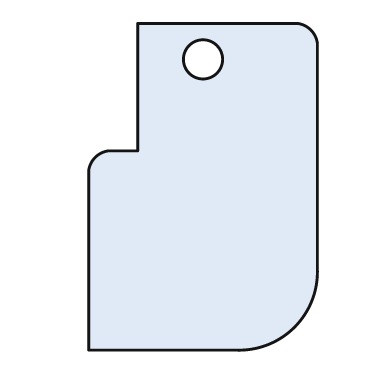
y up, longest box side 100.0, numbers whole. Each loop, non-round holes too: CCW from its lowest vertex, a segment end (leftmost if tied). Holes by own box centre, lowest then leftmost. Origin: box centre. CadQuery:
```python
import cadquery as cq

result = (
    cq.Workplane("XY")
    .moveTo(-35.0, -50.0)
    .lineTo(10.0, -50.0)
    .threePointArc((28.0, -43.0), (35.0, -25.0))
    .lineTo(35.0, 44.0)
    .threePointArc((33.0, 48.0), (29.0, 50.0))
    .lineTo(-20.0, 50.0)
    .lineTo(-20.0, 11.0)
    .lineTo(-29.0, 11.0)
    .threePointArc((-33.0, 9.0), (-35.0, 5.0))
    .close()
    .moveTo(0.0, 39.0)
    .circle(6.0)
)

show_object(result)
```